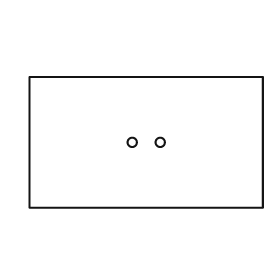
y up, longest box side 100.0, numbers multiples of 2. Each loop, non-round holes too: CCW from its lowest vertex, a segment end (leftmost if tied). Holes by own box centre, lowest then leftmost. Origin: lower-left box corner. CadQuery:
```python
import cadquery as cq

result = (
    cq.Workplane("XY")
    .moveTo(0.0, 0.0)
    .lineTo(100.0, 0.0)
    .lineTo(100.0, 56.0)
    .lineTo(0.0, 56.0)
    .close()
    .moveTo(44.0, 28.0)
    .circle(2.0)
    .moveTo(56.0, 28.0)
    .circle(2.0)
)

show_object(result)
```